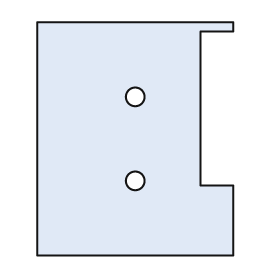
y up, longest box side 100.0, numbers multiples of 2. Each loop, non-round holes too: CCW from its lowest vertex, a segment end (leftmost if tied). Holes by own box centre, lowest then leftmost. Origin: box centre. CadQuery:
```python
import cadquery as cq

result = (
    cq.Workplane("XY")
    .moveTo(-42.0, -50.0)
    .lineTo(42.0, -50.0)
    .lineTo(42.0, -20.0)
    .lineTo(28.0, -20.0)
    .lineTo(28.0, 46.0)
    .lineTo(42.0, 46.0)
    .lineTo(42.0, 50.0)
    .lineTo(-42.0, 50.0)
    .close()
    .moveTo(0.0, -18.0)
    .circle(4.0)
    .moveTo(0.0, 18.0)
    .circle(4.0)
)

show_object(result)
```